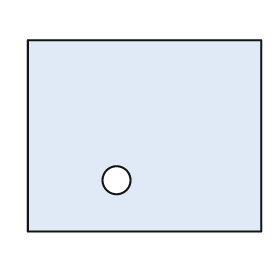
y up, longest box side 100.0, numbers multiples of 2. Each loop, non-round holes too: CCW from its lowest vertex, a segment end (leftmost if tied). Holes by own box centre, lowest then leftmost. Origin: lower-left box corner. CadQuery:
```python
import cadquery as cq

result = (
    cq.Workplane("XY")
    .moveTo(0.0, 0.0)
    .lineTo(100.0, 0.0)
    .lineTo(100.0, 82.0)
    .lineTo(0.0, 82.0)
    .close()
    .moveTo(38.0, 22.0)
    .circle(6.0)
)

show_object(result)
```